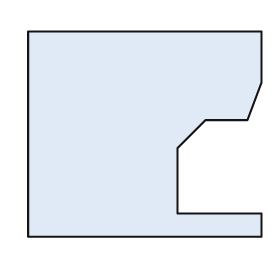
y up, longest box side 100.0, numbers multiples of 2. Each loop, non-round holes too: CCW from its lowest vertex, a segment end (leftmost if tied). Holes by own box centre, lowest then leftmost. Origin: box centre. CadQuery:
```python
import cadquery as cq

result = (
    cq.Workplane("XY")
    .moveTo(-50.0, -44.0)
    .lineTo(50.0, -44.0)
    .lineTo(50.0, -34.0)
    .lineTo(14.0, -34.0)
    .lineTo(14.0, -6.0)
    .lineTo(26.0, 6.0)
    .lineTo(44.0, 6.0)
    .lineTo(50.0, 22.0)
    .lineTo(50.0, 44.0)
    .lineTo(-50.0, 44.0)
    .close()
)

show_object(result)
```